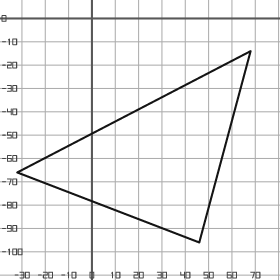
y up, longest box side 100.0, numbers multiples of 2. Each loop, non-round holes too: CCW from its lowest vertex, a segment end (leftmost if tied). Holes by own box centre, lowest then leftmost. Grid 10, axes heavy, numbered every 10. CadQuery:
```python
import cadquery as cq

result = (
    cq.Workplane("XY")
    .moveTo(46.0, -96.0)
    .lineTo(68.0, -14.0)
    .lineTo(-32.0, -66.0)
    .close()
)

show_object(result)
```